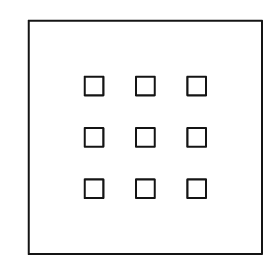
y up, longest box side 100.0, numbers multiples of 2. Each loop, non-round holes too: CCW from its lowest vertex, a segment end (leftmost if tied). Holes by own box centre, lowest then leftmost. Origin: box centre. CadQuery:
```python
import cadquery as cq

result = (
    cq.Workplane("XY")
    .moveTo(-50.0, -50.0)
    .lineTo(50.0, -50.0)
    .lineTo(50.0, 50.0)
    .lineTo(-50.0, 50.0)
    .close()
    .moveTo(-26.0, -26.0)
    .lineTo(-18.0, -26.0)
    .lineTo(-18.0, -18.0)
    .lineTo(-26.0, -18.0)
    .close()
    .moveTo(-4.0, -26.0)
    .lineTo(4.0, -26.0)
    .lineTo(4.0, -18.0)
    .lineTo(-4.0, -18.0)
    .close()
    .moveTo(18.0, -26.0)
    .lineTo(26.0, -26.0)
    .lineTo(26.0, -18.0)
    .lineTo(18.0, -18.0)
    .close()
    .moveTo(-26.0, -4.0)
    .lineTo(-18.0, -4.0)
    .lineTo(-18.0, 4.0)
    .lineTo(-26.0, 4.0)
    .close()
    .moveTo(-4.0, -4.0)
    .lineTo(4.0, -4.0)
    .lineTo(4.0, 4.0)
    .lineTo(-4.0, 4.0)
    .close()
    .moveTo(18.0, -4.0)
    .lineTo(26.0, -4.0)
    .lineTo(26.0, 4.0)
    .lineTo(18.0, 4.0)
    .close()
    .moveTo(-26.0, 18.0)
    .lineTo(-18.0, 18.0)
    .lineTo(-18.0, 26.0)
    .lineTo(-26.0, 26.0)
    .close()
    .moveTo(-4.0, 18.0)
    .lineTo(4.0, 18.0)
    .lineTo(4.0, 26.0)
    .lineTo(-4.0, 26.0)
    .close()
    .moveTo(18.0, 18.0)
    .lineTo(26.0, 18.0)
    .lineTo(26.0, 26.0)
    .lineTo(18.0, 26.0)
    .close()
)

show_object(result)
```